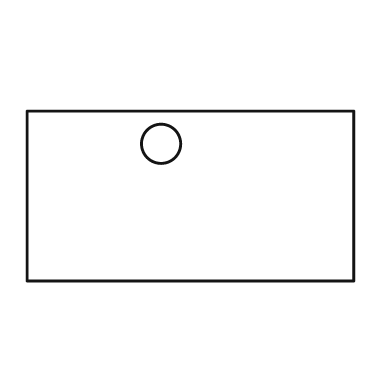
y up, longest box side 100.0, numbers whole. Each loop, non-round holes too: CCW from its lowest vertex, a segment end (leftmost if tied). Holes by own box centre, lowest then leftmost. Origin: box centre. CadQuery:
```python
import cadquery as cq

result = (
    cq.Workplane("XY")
    .moveTo(-50.0, -26.0)
    .lineTo(50.0, -26.0)
    .lineTo(50.0, 26.0)
    .lineTo(-50.0, 26.0)
    .close()
    .moveTo(-9.0, 16.0)
    .circle(6.0)
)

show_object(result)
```